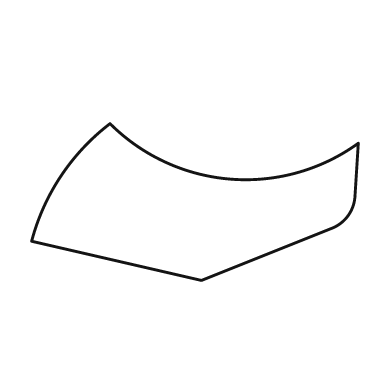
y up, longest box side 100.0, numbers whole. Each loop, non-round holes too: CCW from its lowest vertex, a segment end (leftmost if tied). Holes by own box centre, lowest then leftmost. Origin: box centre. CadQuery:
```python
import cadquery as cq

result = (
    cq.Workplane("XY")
    .moveTo(2.0, -24.0)
    .lineTo(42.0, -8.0)
    .threePointArc((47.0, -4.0), (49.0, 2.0))
    .lineTo(50.0, 18.0)
    .threePointArc((11.0, 7.0), (-26.0, 24.0))
    .threePointArc((-41.0, 8.0), (-50.0, -12.0))
    .close()
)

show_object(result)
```